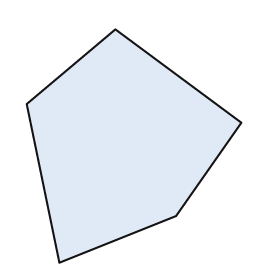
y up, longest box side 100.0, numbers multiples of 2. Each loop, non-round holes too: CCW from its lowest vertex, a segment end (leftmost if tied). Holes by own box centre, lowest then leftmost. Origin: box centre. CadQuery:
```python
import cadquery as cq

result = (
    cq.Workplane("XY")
    .moveTo(-32.0, -50.0)
    .lineTo(18.0, -30.0)
    .lineTo(46.0, 10.0)
    .lineTo(-8.0, 50.0)
    .lineTo(-46.0, 18.0)
    .close()
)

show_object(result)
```